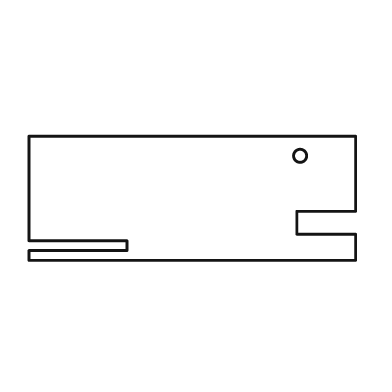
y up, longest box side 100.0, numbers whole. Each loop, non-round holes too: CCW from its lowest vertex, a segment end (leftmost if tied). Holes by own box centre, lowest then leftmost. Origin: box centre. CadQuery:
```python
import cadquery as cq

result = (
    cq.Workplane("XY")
    .moveTo(-50.0, -19.0)
    .lineTo(50.0, -19.0)
    .lineTo(50.0, -11.0)
    .lineTo(32.0, -11.0)
    .lineTo(32.0, -4.0)
    .lineTo(50.0, -4.0)
    .lineTo(50.0, 19.0)
    .lineTo(-50.0, 19.0)
    .lineTo(-50.0, -13.0)
    .lineTo(-20.0, -13.0)
    .lineTo(-20.0, -16.0)
    .lineTo(-50.0, -16.0)
    .close()
    .moveTo(33.0, 13.0)
    .circle(2.0)
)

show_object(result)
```